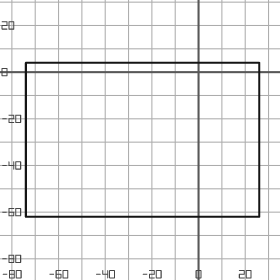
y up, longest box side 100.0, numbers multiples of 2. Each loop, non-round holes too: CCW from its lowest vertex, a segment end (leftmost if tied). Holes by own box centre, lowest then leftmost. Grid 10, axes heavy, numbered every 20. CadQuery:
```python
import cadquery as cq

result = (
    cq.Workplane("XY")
    .moveTo(-74.0, -62.0)
    .lineTo(26.0, -62.0)
    .lineTo(26.0, 4.0)
    .lineTo(-74.0, 4.0)
    .close()
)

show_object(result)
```